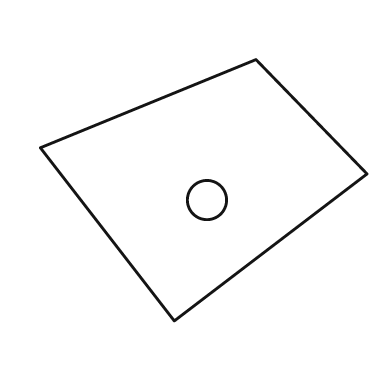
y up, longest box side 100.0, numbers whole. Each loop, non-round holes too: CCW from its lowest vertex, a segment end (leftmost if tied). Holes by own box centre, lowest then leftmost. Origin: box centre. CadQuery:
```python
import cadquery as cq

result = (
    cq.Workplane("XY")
    .moveTo(-9.0, -40.0)
    .lineTo(50.0, 5.0)
    .lineTo(16.0, 40.0)
    .lineTo(-50.0, 13.0)
    .close()
    .moveTo(1.0, -3.0)
    .circle(6.0)
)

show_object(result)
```